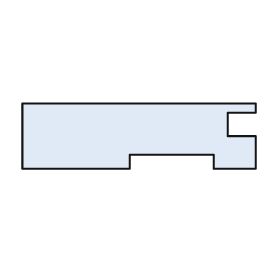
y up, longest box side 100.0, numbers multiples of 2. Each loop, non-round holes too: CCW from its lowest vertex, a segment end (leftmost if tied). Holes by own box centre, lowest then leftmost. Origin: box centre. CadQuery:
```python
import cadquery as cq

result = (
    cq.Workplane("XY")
    .moveTo(-50.0, -14.0)
    .lineTo(-4.0, -14.0)
    .lineTo(-4.0, -8.0)
    .lineTo(32.0, -8.0)
    .lineTo(32.0, -14.0)
    .lineTo(50.0, -14.0)
    .lineTo(50.0, 0.0)
    .lineTo(38.0, 0.0)
    .lineTo(38.0, 10.0)
    .lineTo(50.0, 10.0)
    .lineTo(50.0, 14.0)
    .lineTo(-50.0, 14.0)
    .close()
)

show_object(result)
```